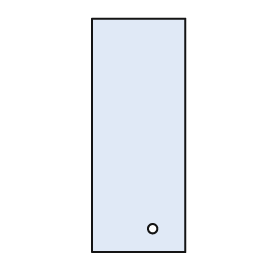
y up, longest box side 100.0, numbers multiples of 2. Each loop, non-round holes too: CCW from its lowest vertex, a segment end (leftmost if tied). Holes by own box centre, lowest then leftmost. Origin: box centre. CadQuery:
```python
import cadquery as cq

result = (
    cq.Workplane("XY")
    .moveTo(-20.0, -50.0)
    .lineTo(20.0, -50.0)
    .lineTo(20.0, 50.0)
    .lineTo(-20.0, 50.0)
    .close()
    .moveTo(6.0, -40.0)
    .circle(2.0)
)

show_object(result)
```